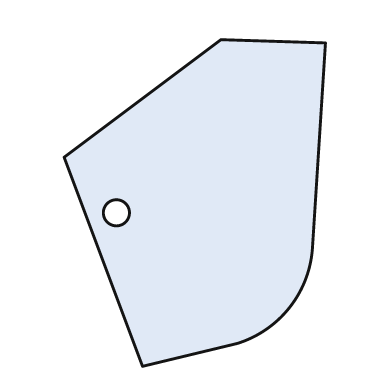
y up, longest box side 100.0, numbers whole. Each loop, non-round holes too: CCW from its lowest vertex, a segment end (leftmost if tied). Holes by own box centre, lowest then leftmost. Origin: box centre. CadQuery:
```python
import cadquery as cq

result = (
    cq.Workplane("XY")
    .moveTo(-16.0, -50.0)
    .lineTo(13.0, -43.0)
    .threePointArc((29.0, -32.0), (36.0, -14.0))
    .lineTo(40.0, 49.0)
    .lineTo(8.0, 50.0)
    .lineTo(-40.0, 14.0)
    .close()
    .moveTo(-24.0, -3.0)
    .circle(4.0)
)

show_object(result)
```